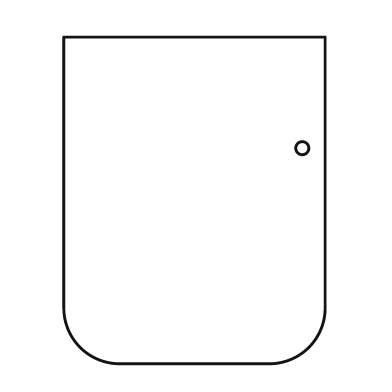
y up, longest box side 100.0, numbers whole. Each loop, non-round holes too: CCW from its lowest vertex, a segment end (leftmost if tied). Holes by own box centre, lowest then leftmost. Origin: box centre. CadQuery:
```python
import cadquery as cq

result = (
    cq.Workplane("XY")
    .moveTo(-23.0, -50.0)
    .lineTo(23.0, -50.0)
    .threePointArc((35.0, -45.0), (40.0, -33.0))
    .lineTo(40.0, 50.0)
    .lineTo(-40.0, 50.0)
    .lineTo(-40.0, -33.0)
    .threePointArc((-35.0, -45.0), (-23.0, -50.0))
    .close()
    .moveTo(33.0, 16.0)
    .circle(2.0)
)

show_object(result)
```